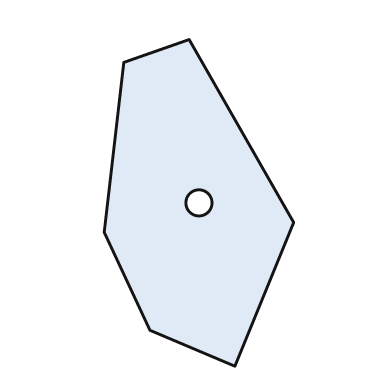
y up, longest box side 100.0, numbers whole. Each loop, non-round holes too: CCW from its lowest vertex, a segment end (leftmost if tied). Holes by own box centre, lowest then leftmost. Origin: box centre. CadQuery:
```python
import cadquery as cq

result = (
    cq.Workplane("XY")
    .moveTo(11.0, -50.0)
    .lineTo(29.0, -6.0)
    .lineTo(-3.0, 50.0)
    .lineTo(-23.0, 43.0)
    .lineTo(-29.0, -9.0)
    .lineTo(-15.0, -39.0)
    .close()
    .moveTo(0.0, 0.0)
    .circle(4.0)
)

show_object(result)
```